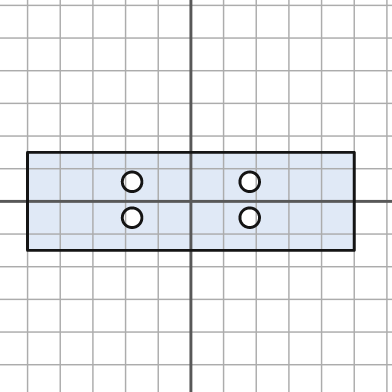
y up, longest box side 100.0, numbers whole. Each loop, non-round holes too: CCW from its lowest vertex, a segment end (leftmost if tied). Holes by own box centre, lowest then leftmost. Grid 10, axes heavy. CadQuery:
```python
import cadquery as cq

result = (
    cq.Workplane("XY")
    .moveTo(-50.0, -15.0)
    .lineTo(50.0, -15.0)
    .lineTo(50.0, 15.0)
    .lineTo(-50.0, 15.0)
    .close()
    .moveTo(-18.0, -5.0)
    .circle(3.0)
    .moveTo(18.0, -5.0)
    .circle(3.0)
    .moveTo(-18.0, 6.0)
    .circle(3.0)
    .moveTo(18.0, 6.0)
    .circle(3.0)
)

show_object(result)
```